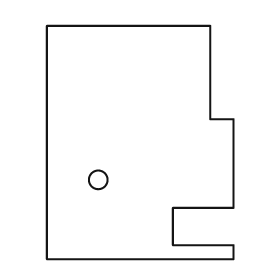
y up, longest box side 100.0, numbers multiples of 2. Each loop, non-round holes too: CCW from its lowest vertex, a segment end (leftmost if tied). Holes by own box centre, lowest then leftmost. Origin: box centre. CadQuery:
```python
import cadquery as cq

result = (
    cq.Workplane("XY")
    .moveTo(-40.0, -50.0)
    .lineTo(40.0, -50.0)
    .lineTo(40.0, -44.0)
    .lineTo(14.0, -44.0)
    .lineTo(14.0, -28.0)
    .lineTo(40.0, -28.0)
    .lineTo(40.0, 10.0)
    .lineTo(30.0, 10.0)
    .lineTo(30.0, 50.0)
    .lineTo(-40.0, 50.0)
    .close()
    .moveTo(-18.0, -16.0)
    .circle(4.0)
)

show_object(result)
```